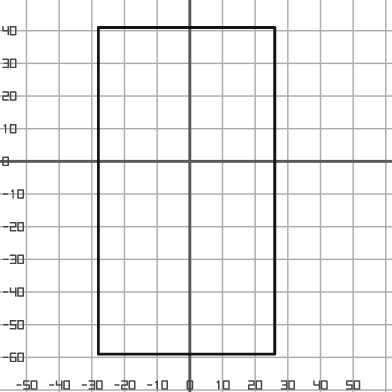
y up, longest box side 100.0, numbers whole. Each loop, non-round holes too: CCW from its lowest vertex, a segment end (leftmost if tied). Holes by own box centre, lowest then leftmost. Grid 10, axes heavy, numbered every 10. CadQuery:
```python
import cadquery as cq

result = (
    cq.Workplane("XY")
    .moveTo(-28.0, -59.0)
    .lineTo(26.0, -59.0)
    .lineTo(26.0, 41.0)
    .lineTo(-28.0, 41.0)
    .close()
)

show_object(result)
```